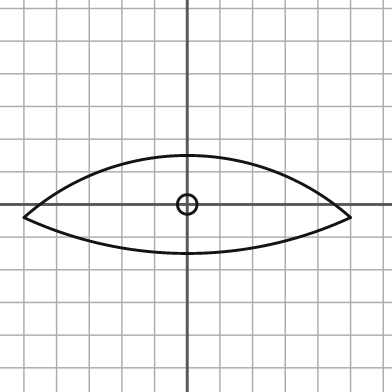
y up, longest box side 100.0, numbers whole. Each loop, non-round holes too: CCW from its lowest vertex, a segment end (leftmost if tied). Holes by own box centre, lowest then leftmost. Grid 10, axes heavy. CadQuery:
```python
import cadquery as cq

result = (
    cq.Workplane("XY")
    .moveTo(-50.0, -4.0)
    .threePointArc((0.0, -15.0), (50.0, -4.0))
    .threePointArc((0.0, 15.0), (-50.0, -4.0))
    .close()
    .moveTo(0.0, 0.0)
    .circle(3.0)
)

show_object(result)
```